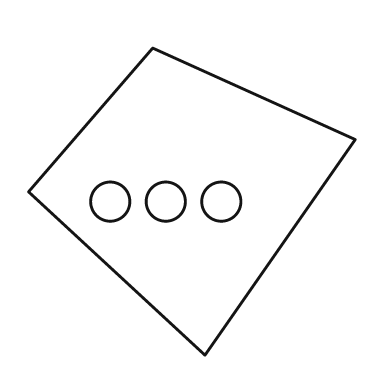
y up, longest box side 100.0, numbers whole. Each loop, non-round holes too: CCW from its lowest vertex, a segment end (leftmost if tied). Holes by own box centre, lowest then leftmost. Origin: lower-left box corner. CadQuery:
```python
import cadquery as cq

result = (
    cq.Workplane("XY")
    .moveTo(54.0, 0.0)
    .lineTo(100.0, 66.0)
    .lineTo(38.0, 94.0)
    .lineTo(0.0, 50.0)
    .close()
    .moveTo(25.0, 47.0)
    .circle(6.0)
    .moveTo(42.0, 47.0)
    .circle(6.0)
    .moveTo(59.0, 47.0)
    .circle(6.0)
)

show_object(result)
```